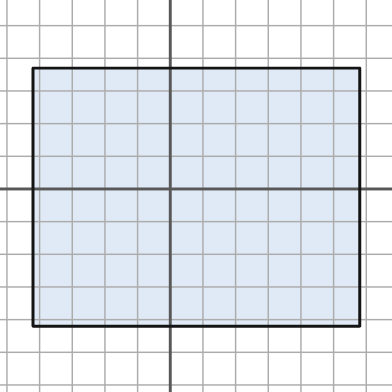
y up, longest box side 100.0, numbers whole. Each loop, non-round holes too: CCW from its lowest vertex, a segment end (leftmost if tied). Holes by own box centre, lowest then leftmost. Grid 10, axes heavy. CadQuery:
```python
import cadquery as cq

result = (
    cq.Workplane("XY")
    .moveTo(-42.0, -42.0)
    .lineTo(58.0, -42.0)
    .lineTo(58.0, 37.0)
    .lineTo(-42.0, 37.0)
    .close()
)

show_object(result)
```